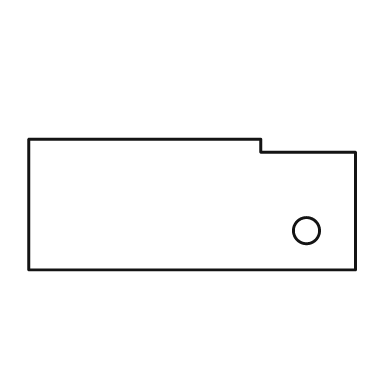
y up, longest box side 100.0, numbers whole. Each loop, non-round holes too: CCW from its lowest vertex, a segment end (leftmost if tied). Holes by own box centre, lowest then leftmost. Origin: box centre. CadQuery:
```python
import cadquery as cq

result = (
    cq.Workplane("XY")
    .moveTo(-50.0, -20.0)
    .lineTo(50.0, -20.0)
    .lineTo(50.0, 16.0)
    .lineTo(21.0, 16.0)
    .lineTo(21.0, 20.0)
    .lineTo(-50.0, 20.0)
    .close()
    .moveTo(35.0, -8.0)
    .circle(4.0)
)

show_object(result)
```